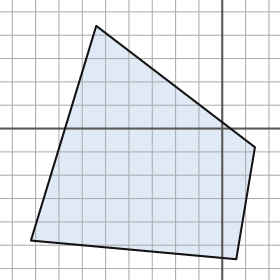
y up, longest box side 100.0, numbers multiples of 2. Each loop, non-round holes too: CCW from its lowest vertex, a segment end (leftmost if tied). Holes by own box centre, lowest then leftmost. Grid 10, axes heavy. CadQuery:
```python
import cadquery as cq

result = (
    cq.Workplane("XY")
    .moveTo(6.0, -56.0)
    .lineTo(14.0, -8.0)
    .lineTo(-54.0, 44.0)
    .lineTo(-82.0, -48.0)
    .close()
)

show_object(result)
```